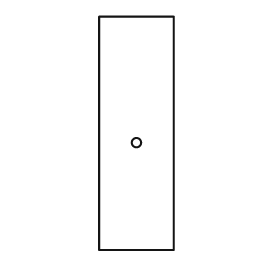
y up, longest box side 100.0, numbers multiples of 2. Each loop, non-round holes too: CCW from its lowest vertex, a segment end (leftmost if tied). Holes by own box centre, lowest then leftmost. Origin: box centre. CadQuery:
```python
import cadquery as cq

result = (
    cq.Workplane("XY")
    .moveTo(-16.0, -50.0)
    .lineTo(16.0, -50.0)
    .lineTo(16.0, 50.0)
    .lineTo(-16.0, 50.0)
    .close()
    .moveTo(0.0, -4.0)
    .circle(2.0)
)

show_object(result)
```